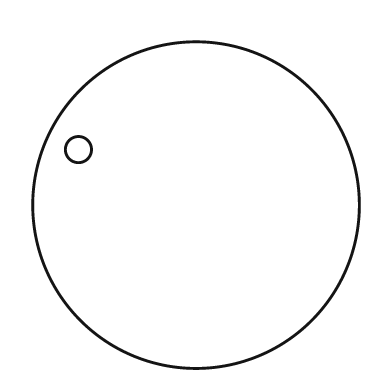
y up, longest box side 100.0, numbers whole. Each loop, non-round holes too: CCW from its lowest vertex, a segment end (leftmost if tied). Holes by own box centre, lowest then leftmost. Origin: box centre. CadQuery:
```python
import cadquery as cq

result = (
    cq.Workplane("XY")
    .moveTo(0.0, 0.0)
    .circle(50.0)
    .moveTo(-36.0, 17.0)
    .circle(4.0)
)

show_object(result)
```